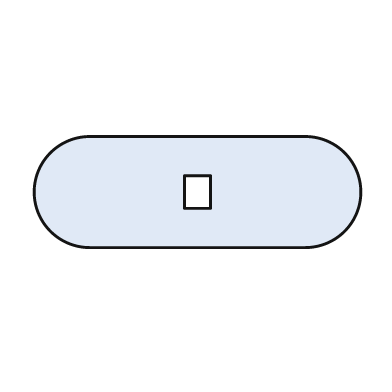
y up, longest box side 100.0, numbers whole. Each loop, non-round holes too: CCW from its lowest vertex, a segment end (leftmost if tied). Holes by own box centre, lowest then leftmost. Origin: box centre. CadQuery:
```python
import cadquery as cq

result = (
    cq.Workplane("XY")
    .moveTo(-33.0, -17.0)
    .lineTo(33.0, -17.0)
    .threePointArc((50.0, 0.0), (33.0, 17.0))
    .lineTo(-33.0, 17.0)
    .threePointArc((-50.0, 0.0), (-33.0, -17.0))
    .close()
    .moveTo(-4.0, -5.0)
    .lineTo(4.0, -5.0)
    .lineTo(4.0, 5.0)
    .lineTo(-4.0, 5.0)
    .close()
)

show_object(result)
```